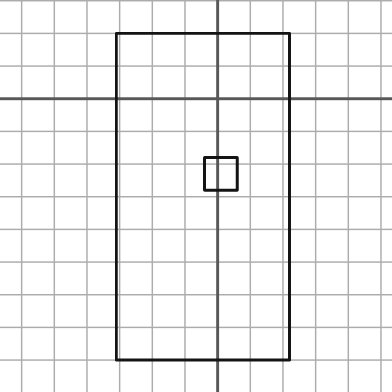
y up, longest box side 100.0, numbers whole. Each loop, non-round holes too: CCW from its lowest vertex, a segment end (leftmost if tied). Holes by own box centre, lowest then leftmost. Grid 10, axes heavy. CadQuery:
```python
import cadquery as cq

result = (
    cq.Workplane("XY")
    .moveTo(-31.0, -80.0)
    .lineTo(22.0, -80.0)
    .lineTo(22.0, 20.0)
    .lineTo(-31.0, 20.0)
    .close()
    .moveTo(-4.0, -28.0)
    .lineTo(6.0, -28.0)
    .lineTo(6.0, -18.0)
    .lineTo(-4.0, -18.0)
    .close()
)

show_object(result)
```